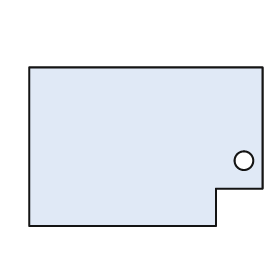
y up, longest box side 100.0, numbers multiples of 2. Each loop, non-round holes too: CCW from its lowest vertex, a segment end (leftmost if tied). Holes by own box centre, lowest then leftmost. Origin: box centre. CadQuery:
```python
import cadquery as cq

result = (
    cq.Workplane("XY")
    .moveTo(-50.0, -34.0)
    .lineTo(30.0, -34.0)
    .lineTo(30.0, -18.0)
    .lineTo(50.0, -18.0)
    .lineTo(50.0, 34.0)
    .lineTo(-50.0, 34.0)
    .close()
    .moveTo(42.0, -6.0)
    .circle(4.0)
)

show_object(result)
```